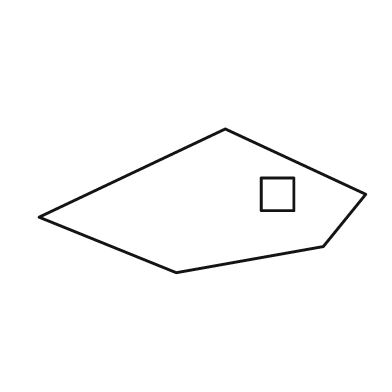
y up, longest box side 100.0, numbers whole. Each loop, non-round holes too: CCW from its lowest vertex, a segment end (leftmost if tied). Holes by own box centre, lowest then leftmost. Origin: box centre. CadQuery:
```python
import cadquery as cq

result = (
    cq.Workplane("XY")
    .moveTo(-8.0, -22.0)
    .lineTo(37.0, -14.0)
    .lineTo(50.0, 2.0)
    .lineTo(7.0, 22.0)
    .lineTo(-50.0, -5.0)
    .close()
    .moveTo(18.0, -3.0)
    .lineTo(28.0, -3.0)
    .lineTo(28.0, 7.0)
    .lineTo(18.0, 7.0)
    .close()
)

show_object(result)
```